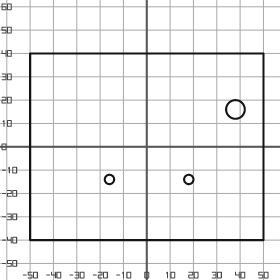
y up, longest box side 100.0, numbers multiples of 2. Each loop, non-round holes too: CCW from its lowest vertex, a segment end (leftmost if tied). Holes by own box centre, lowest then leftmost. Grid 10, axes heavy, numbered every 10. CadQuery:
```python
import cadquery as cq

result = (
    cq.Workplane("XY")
    .moveTo(-50.0, -40.0)
    .lineTo(50.0, -40.0)
    .lineTo(50.0, 40.0)
    .lineTo(-50.0, 40.0)
    .close()
    .moveTo(-16.0, -14.0)
    .circle(2.0)
    .moveTo(18.0, -14.0)
    .circle(2.0)
    .moveTo(38.0, 16.0)
    .circle(4.0)
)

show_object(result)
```